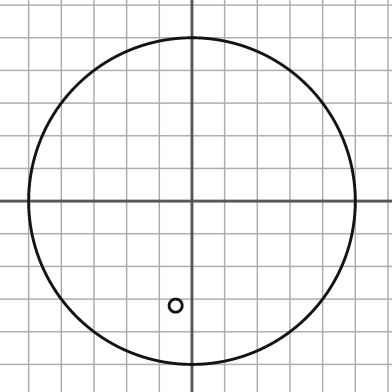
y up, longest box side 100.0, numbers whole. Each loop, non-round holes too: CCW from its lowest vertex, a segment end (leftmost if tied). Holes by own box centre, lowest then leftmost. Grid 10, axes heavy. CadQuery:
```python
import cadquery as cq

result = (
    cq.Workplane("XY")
    .moveTo(0.0, 0.0)
    .circle(50.0)
    .moveTo(-5.0, -32.0)
    .circle(2.0)
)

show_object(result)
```